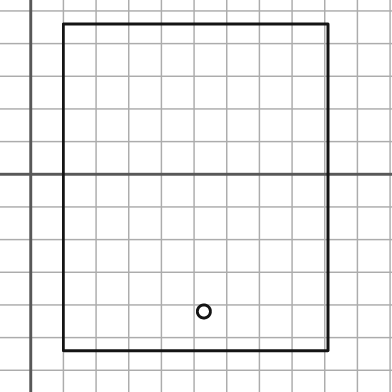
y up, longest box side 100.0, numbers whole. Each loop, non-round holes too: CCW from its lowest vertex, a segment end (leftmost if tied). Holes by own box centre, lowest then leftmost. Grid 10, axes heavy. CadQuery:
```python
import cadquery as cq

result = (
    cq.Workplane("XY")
    .moveTo(10.0, -54.0)
    .lineTo(91.0, -54.0)
    .lineTo(91.0, 46.0)
    .lineTo(10.0, 46.0)
    .close()
    .moveTo(53.0, -42.0)
    .circle(2.0)
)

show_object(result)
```